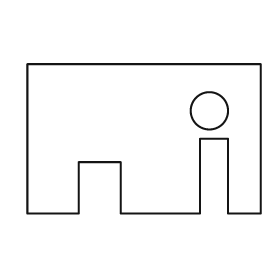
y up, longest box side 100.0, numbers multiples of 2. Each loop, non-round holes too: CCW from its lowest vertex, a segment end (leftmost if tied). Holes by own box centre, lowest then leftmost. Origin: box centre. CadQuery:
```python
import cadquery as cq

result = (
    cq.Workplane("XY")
    .moveTo(-50.0, -32.0)
    .lineTo(-28.0, -32.0)
    .lineTo(-28.0, -10.0)
    .lineTo(-10.0, -10.0)
    .lineTo(-10.0, -32.0)
    .lineTo(24.0, -32.0)
    .lineTo(24.0, 0.0)
    .lineTo(36.0, 0.0)
    .lineTo(36.0, -32.0)
    .lineTo(50.0, -32.0)
    .lineTo(50.0, 32.0)
    .lineTo(-50.0, 32.0)
    .close()
    .moveTo(28.0, 12.0)
    .circle(8.0)
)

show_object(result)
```